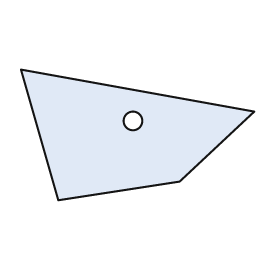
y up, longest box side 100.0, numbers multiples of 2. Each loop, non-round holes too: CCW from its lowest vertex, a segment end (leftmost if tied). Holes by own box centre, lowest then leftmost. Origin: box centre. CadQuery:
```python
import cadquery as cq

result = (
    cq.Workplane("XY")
    .moveTo(-34.0, -28.0)
    .lineTo(18.0, -20.0)
    .lineTo(50.0, 10.0)
    .lineTo(-50.0, 28.0)
    .close()
    .moveTo(-2.0, 6.0)
    .circle(4.0)
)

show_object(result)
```